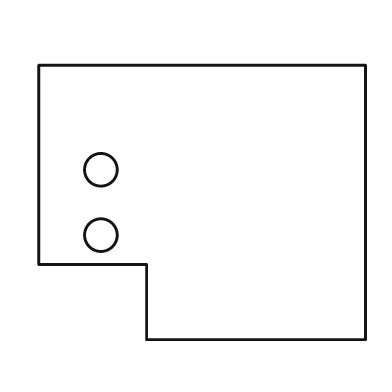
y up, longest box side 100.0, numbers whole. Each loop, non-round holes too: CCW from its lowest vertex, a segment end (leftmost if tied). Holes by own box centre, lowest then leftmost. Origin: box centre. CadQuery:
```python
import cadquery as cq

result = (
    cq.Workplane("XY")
    .moveTo(-17.0, -42.0)
    .lineTo(50.0, -42.0)
    .lineTo(50.0, 42.0)
    .lineTo(-50.0, 42.0)
    .lineTo(-50.0, -19.0)
    .lineTo(-17.0, -19.0)
    .close()
    .moveTo(-31.0, -10.0)
    .circle(5.0)
    .moveTo(-31.0, 10.0)
    .circle(5.0)
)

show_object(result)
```